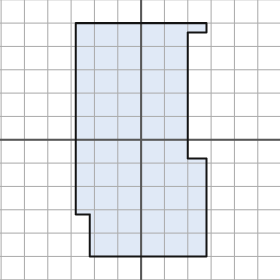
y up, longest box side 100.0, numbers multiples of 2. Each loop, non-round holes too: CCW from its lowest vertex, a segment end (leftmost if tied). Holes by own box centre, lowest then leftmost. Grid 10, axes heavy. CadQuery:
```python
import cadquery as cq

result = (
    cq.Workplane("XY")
    .moveTo(-22.0, -50.0)
    .lineTo(28.0, -50.0)
    .lineTo(28.0, -8.0)
    .lineTo(20.0, -8.0)
    .lineTo(20.0, 46.0)
    .lineTo(28.0, 46.0)
    .lineTo(28.0, 50.0)
    .lineTo(-28.0, 50.0)
    .lineTo(-28.0, -32.0)
    .lineTo(-22.0, -32.0)
    .close()
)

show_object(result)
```